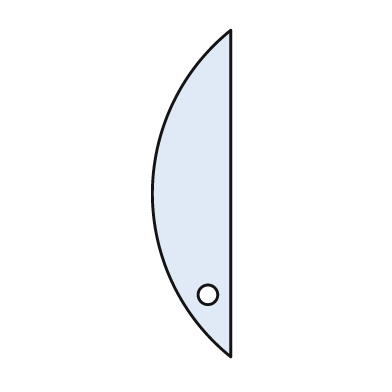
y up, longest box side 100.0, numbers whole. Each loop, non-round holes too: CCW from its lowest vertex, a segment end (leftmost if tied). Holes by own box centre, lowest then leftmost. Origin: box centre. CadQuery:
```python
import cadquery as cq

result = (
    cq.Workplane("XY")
    .moveTo(12.0, -50.0)
    .lineTo(12.0, 50.0)
    .threePointArc((-12.0, 0.0), (12.0, -50.0))
    .close()
    .moveTo(5.0, -31.0)
    .circle(3.0)
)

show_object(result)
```